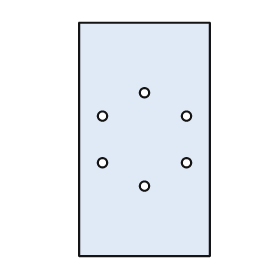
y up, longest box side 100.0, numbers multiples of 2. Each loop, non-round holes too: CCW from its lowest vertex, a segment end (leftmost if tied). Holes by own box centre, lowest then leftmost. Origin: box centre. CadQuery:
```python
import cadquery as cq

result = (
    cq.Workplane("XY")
    .moveTo(-28.0, -50.0)
    .lineTo(28.0, -50.0)
    .lineTo(28.0, 50.0)
    .lineTo(-28.0, 50.0)
    .close()
    .moveTo(0.0, -20.0)
    .circle(2.0)
    .moveTo(-18.0, -10.0)
    .circle(2.0)
    .moveTo(18.0, -10.0)
    .circle(2.0)
    .moveTo(-18.0, 10.0)
    .circle(2.0)
    .moveTo(18.0, 10.0)
    .circle(2.0)
    .moveTo(0.0, 20.0)
    .circle(2.0)
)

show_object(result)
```